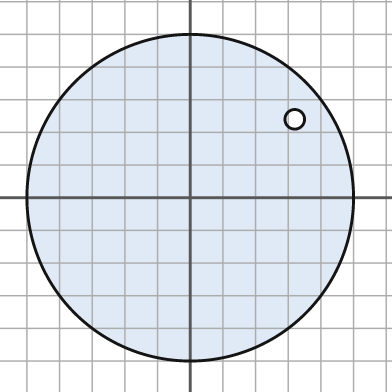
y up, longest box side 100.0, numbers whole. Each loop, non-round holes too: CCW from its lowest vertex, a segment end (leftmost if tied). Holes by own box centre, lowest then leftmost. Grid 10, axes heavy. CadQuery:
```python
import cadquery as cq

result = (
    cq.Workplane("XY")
    .moveTo(0.0, 0.0)
    .circle(50.0)
    .moveTo(32.0, 24.0)
    .circle(3.0)
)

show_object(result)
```